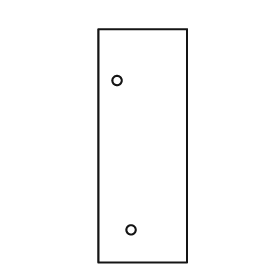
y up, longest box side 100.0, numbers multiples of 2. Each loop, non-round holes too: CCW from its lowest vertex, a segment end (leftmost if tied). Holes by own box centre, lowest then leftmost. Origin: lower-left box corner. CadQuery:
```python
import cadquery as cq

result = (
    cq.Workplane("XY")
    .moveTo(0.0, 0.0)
    .lineTo(38.0, 0.0)
    .lineTo(38.0, 100.0)
    .lineTo(0.0, 100.0)
    .close()
    .moveTo(14.0, 14.0)
    .circle(2.0)
    .moveTo(8.0, 78.0)
    .circle(2.0)
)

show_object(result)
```